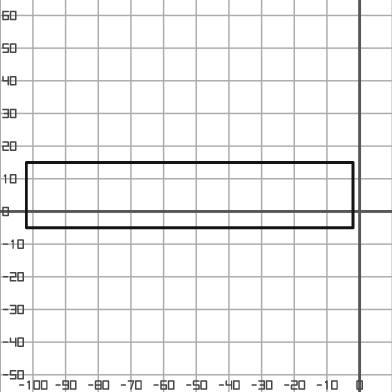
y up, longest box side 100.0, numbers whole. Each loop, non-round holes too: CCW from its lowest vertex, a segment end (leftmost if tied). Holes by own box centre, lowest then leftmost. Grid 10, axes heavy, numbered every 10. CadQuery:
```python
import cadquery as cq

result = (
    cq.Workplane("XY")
    .moveTo(-102.0, -5.0)
    .lineTo(-2.0, -5.0)
    .lineTo(-2.0, 15.0)
    .lineTo(-102.0, 15.0)
    .close()
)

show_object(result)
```